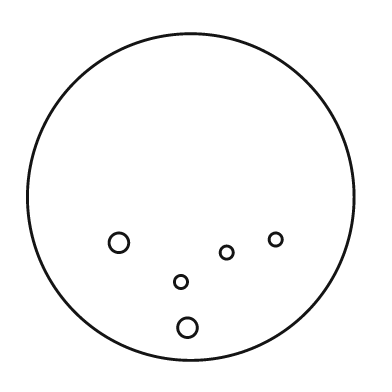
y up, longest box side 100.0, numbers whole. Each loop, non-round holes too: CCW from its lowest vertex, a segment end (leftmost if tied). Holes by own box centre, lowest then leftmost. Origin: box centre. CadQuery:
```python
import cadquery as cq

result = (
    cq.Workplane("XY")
    .moveTo(0.0, 0.0)
    .circle(50.0)
    .moveTo(-1.0, -40.0)
    .circle(3.0)
    .moveTo(-3.0, -26.0)
    .circle(2.0)
    .moveTo(11.0, -17.0)
    .circle(2.0)
    .moveTo(-22.0, -14.0)
    .circle(3.0)
    .moveTo(26.0, -13.0)
    .circle(2.0)
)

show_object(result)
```